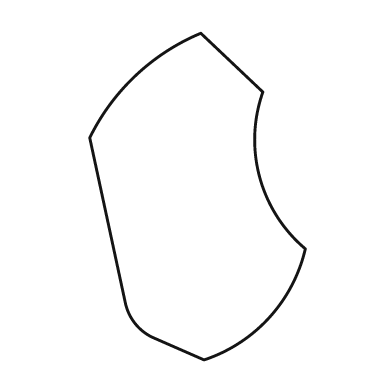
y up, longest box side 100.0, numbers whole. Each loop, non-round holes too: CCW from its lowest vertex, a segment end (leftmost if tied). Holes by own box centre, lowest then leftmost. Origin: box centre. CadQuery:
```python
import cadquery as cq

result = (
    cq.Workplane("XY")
    .moveTo(2.0, -50.0)
    .threePointArc((22.0, -37.0), (33.0, -16.0))
    .threePointArc((19.0, 6.0), (20.0, 32.0))
    .lineTo(1.0, 50.0)
    .threePointArc((-19.0, 37.0), (-33.0, 18.0))
    .lineTo(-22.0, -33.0)
    .threePointArc((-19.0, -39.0), (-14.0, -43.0))
    .close()
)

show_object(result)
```